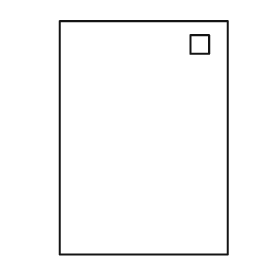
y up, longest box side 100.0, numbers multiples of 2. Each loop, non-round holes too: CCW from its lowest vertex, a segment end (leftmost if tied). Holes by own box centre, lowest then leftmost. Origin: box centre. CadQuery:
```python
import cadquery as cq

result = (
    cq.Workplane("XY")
    .moveTo(-36.0, -50.0)
    .lineTo(36.0, -50.0)
    .lineTo(36.0, 50.0)
    .lineTo(-36.0, 50.0)
    .close()
    .moveTo(20.0, 36.0)
    .lineTo(28.0, 36.0)
    .lineTo(28.0, 44.0)
    .lineTo(20.0, 44.0)
    .close()
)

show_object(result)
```